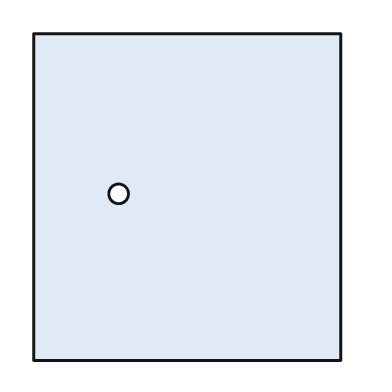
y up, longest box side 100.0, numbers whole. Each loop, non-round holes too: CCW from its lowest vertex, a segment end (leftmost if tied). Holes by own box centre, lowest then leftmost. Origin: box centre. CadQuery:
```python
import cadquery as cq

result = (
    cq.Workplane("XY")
    .moveTo(-47.0, -50.0)
    .lineTo(47.0, -50.0)
    .lineTo(47.0, 50.0)
    .lineTo(-47.0, 50.0)
    .close()
    .moveTo(-21.0, 1.0)
    .circle(3.0)
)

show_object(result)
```